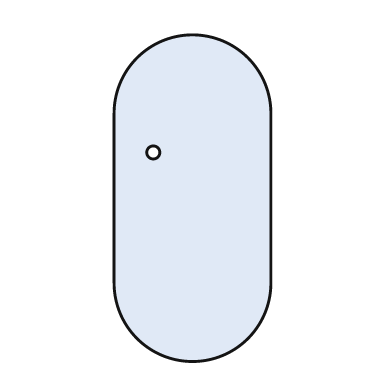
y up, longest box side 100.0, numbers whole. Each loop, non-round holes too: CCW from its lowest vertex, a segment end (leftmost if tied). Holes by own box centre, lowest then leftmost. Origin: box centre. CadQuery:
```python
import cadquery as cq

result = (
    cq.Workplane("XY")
    .moveTo(-24.0, -26.0)
    .threePointArc((0.0, -50.0), (24.0, -26.0))
    .lineTo(24.0, 26.0)
    .threePointArc((0.0, 50.0), (-24.0, 26.0))
    .close()
    .moveTo(-12.0, 14.0)
    .circle(2.0)
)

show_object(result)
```